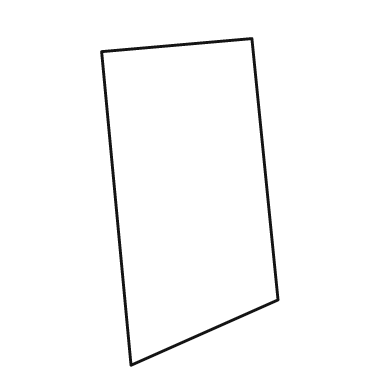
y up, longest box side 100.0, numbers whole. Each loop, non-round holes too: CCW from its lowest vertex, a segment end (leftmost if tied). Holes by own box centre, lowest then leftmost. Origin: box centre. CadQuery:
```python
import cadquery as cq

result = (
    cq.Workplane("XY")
    .moveTo(-18.0, -50.0)
    .lineTo(27.0, -30.0)
    .lineTo(19.0, 50.0)
    .lineTo(-27.0, 46.0)
    .close()
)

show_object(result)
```